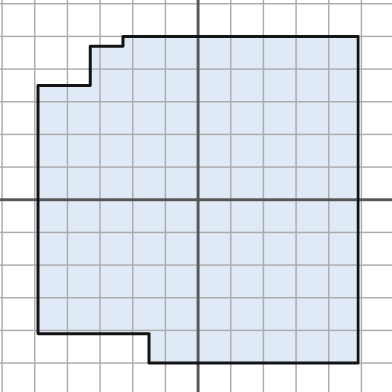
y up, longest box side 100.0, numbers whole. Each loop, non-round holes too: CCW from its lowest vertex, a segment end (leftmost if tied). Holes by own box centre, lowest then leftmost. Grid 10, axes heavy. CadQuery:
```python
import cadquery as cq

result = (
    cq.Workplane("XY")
    .moveTo(-15.0, -50.0)
    .lineTo(49.0, -50.0)
    .lineTo(49.0, 50.0)
    .lineTo(-23.0, 50.0)
    .lineTo(-23.0, 47.0)
    .lineTo(-33.0, 47.0)
    .lineTo(-33.0, 35.0)
    .lineTo(-49.0, 35.0)
    .lineTo(-49.0, -41.0)
    .lineTo(-15.0, -41.0)
    .close()
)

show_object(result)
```